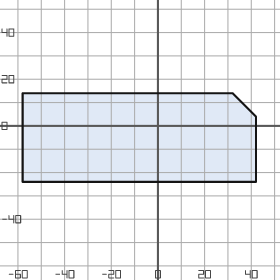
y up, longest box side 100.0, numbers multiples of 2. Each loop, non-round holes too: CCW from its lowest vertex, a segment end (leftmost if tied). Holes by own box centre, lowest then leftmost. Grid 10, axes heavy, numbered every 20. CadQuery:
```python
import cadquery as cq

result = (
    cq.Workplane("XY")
    .moveTo(-58.0, -24.0)
    .lineTo(42.0, -24.0)
    .lineTo(42.0, 4.0)
    .lineTo(32.0, 14.0)
    .lineTo(-58.0, 14.0)
    .close()
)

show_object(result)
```